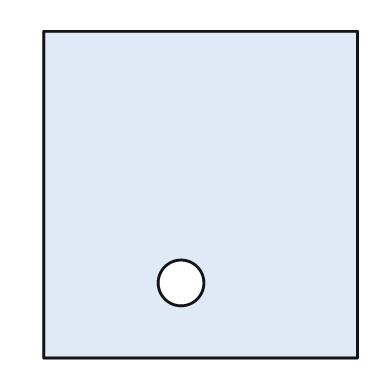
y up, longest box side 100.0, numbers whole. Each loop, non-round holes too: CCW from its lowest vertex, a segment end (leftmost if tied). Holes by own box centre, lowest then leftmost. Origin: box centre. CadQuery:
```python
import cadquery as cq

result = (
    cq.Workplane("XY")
    .moveTo(-48.0, -50.0)
    .lineTo(48.0, -50.0)
    .lineTo(48.0, 50.0)
    .lineTo(-48.0, 50.0)
    .close()
    .moveTo(-6.0, -27.0)
    .circle(7.0)
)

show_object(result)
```